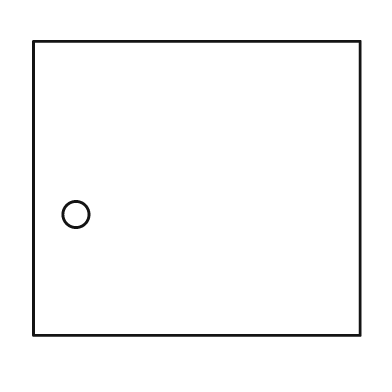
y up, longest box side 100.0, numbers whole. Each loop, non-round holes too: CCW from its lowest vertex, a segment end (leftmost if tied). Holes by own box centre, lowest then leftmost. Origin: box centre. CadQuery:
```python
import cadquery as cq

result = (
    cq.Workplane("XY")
    .moveTo(-50.0, -45.0)
    .lineTo(50.0, -45.0)
    .lineTo(50.0, 45.0)
    .lineTo(-50.0, 45.0)
    .close()
    .moveTo(-37.0, -8.0)
    .circle(4.0)
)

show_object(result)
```